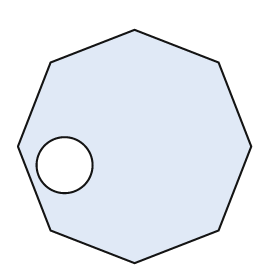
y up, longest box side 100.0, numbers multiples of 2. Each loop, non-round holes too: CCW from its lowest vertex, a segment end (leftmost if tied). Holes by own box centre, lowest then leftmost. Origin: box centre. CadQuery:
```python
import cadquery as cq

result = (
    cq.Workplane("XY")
    .moveTo(0.0, -50.0)
    .lineTo(36.0, -36.0)
    .lineTo(50.0, 0.0)
    .lineTo(36.0, 36.0)
    .lineTo(0.0, 50.0)
    .lineTo(-36.0, 36.0)
    .lineTo(-50.0, 0.0)
    .lineTo(-36.0, -36.0)
    .close()
    .moveTo(-30.0, -8.0)
    .circle(12.0)
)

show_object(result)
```